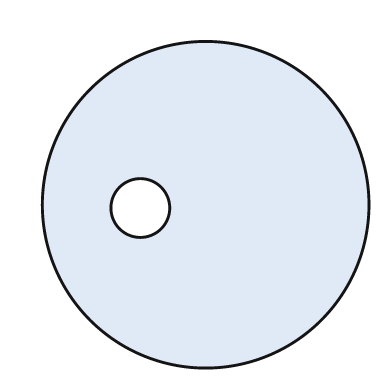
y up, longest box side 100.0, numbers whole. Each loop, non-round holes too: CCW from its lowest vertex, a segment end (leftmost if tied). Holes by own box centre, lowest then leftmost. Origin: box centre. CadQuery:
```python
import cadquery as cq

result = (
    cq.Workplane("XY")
    .moveTo(0.0, 0.0)
    .circle(50.0)
    .moveTo(-20.0, -1.0)
    .circle(9.0)
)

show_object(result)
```